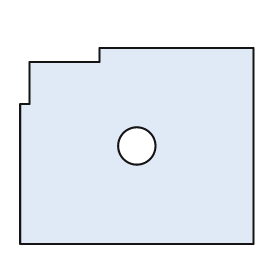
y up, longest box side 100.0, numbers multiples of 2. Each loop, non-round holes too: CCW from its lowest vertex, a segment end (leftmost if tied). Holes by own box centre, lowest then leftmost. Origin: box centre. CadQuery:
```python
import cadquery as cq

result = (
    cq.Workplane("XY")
    .moveTo(-50.0, -42.0)
    .lineTo(50.0, -42.0)
    .lineTo(50.0, 42.0)
    .lineTo(-16.0, 42.0)
    .lineTo(-16.0, 36.0)
    .lineTo(-46.0, 36.0)
    .lineTo(-46.0, 18.0)
    .lineTo(-50.0, 18.0)
    .close()
    .moveTo(0.0, 0.0)
    .circle(8.0)
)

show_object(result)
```